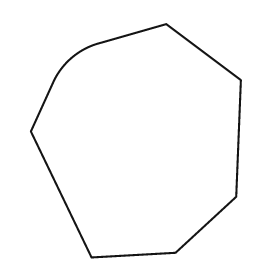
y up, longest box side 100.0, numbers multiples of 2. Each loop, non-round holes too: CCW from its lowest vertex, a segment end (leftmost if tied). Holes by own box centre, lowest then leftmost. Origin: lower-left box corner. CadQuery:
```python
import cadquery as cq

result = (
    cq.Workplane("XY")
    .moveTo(26.0, 0.0)
    .lineTo(62.0, 2.0)
    .lineTo(88.0, 26.0)
    .lineTo(90.0, 76.0)
    .lineTo(58.0, 100.0)
    .lineTo(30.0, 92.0)
    .threePointArc((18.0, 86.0), (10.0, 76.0))
    .lineTo(0.0, 54.0)
    .close()
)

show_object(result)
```